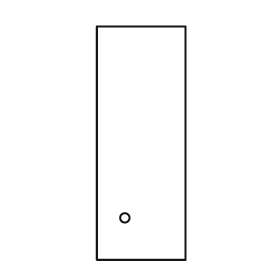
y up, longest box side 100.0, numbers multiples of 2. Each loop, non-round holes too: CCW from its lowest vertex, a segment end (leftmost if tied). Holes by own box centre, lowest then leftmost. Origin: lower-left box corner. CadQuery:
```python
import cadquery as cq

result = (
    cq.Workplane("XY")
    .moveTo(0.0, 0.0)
    .lineTo(38.0, 0.0)
    .lineTo(38.0, 100.0)
    .lineTo(0.0, 100.0)
    .close()
    .moveTo(12.0, 18.0)
    .circle(2.0)
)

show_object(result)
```